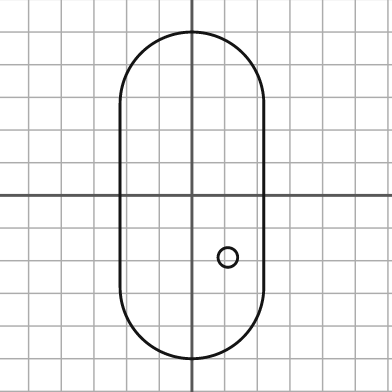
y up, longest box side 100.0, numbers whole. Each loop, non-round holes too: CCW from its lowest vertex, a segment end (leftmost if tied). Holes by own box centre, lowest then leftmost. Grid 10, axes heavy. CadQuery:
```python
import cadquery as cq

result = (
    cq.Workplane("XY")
    .moveTo(-22.0, -28.0)
    .threePointArc((0.0, -50.0), (22.0, -28.0))
    .lineTo(22.0, 28.0)
    .threePointArc((0.0, 50.0), (-22.0, 28.0))
    .close()
    .moveTo(11.0, -19.0)
    .circle(3.0)
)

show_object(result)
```